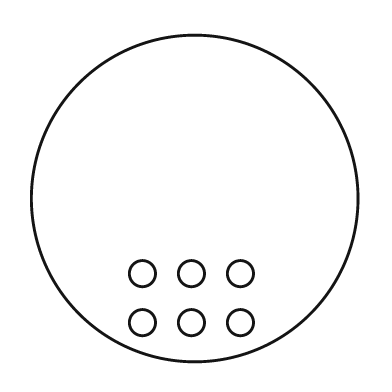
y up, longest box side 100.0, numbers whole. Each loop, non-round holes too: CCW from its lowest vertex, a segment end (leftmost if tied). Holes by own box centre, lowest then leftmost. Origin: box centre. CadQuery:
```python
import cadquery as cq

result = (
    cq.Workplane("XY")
    .moveTo(0.0, 0.0)
    .circle(50.0)
    .moveTo(-16.0, -38.0)
    .circle(4.0)
    .moveTo(-1.0, -38.0)
    .circle(4.0)
    .moveTo(14.0, -38.0)
    .circle(4.0)
    .moveTo(-16.0, -23.0)
    .circle(4.0)
    .moveTo(-1.0, -23.0)
    .circle(4.0)
    .moveTo(14.0, -23.0)
    .circle(4.0)
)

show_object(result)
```